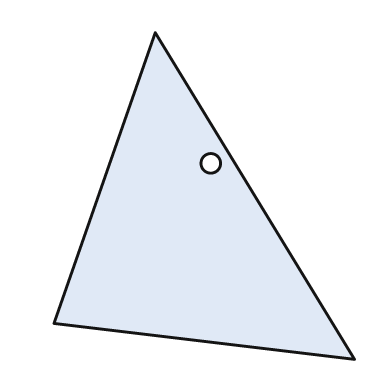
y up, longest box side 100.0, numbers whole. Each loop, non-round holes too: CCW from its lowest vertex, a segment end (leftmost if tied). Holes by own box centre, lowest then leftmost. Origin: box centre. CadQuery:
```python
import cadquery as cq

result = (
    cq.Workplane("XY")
    .moveTo(46.0, -50.0)
    .lineTo(-15.0, 50.0)
    .lineTo(-46.0, -39.0)
    .close()
    .moveTo(2.0, 10.0)
    .circle(3.0)
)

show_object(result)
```